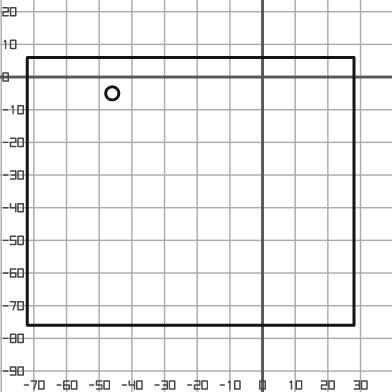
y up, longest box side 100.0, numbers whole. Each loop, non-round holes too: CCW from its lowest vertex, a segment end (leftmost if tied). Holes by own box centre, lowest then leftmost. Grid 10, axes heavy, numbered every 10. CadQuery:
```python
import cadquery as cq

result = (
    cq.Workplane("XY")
    .moveTo(-72.0, -76.0)
    .lineTo(28.0, -76.0)
    .lineTo(28.0, 6.0)
    .lineTo(-72.0, 6.0)
    .close()
    .moveTo(-46.0, -5.0)
    .circle(2.0)
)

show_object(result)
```